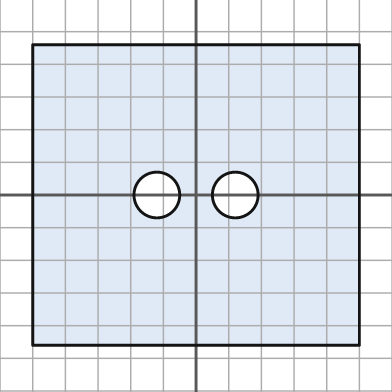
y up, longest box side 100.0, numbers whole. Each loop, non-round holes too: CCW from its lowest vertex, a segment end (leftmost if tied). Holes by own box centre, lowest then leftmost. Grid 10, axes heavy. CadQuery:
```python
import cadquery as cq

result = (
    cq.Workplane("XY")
    .moveTo(-50.0, -46.0)
    .lineTo(50.0, -46.0)
    .lineTo(50.0, 46.0)
    .lineTo(-50.0, 46.0)
    .close()
    .moveTo(-12.0, 0.0)
    .circle(7.0)
    .moveTo(12.0, 0.0)
    .circle(7.0)
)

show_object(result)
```